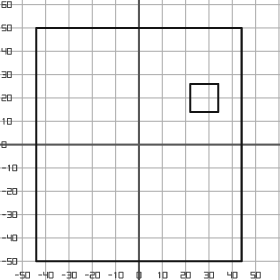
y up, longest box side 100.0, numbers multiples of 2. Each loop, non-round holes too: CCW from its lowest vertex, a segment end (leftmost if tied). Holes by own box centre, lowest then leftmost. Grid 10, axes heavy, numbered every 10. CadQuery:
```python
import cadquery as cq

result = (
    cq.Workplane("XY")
    .moveTo(-44.0, -50.0)
    .lineTo(44.0, -50.0)
    .lineTo(44.0, 50.0)
    .lineTo(-44.0, 50.0)
    .close()
    .moveTo(22.0, 14.0)
    .lineTo(34.0, 14.0)
    .lineTo(34.0, 26.0)
    .lineTo(22.0, 26.0)
    .close()
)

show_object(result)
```